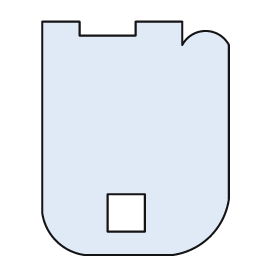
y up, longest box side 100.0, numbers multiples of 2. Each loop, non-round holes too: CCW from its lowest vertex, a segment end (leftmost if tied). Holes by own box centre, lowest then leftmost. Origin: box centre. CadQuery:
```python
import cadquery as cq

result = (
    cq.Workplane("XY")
    .moveTo(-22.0, -50.0)
    .lineTo(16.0, -50.0)
    .threePointArc((32.0, -42.0), (40.0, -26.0))
    .lineTo(40.0, 40.0)
    .threePointArc((30.0, 46.0), (20.0, 40.0))
    .lineTo(20.0, 50.0)
    .lineTo(0.0, 50.0)
    .lineTo(0.0, 44.0)
    .lineTo(-24.0, 44.0)
    .lineTo(-24.0, 50.0)
    .lineTo(-40.0, 50.0)
    .lineTo(-40.0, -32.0)
    .threePointArc((-34.0, -44.0), (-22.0, -50.0))
    .close()
    .moveTo(-12.0, -40.0)
    .lineTo(4.0, -40.0)
    .lineTo(4.0, -24.0)
    .lineTo(-12.0, -24.0)
    .close()
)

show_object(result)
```